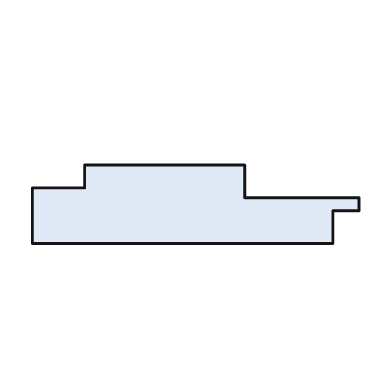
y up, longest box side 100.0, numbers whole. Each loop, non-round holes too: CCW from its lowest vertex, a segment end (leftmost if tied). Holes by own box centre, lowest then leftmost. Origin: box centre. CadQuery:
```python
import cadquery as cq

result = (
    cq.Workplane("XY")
    .moveTo(-50.0, -12.0)
    .lineTo(42.0, -12.0)
    .lineTo(42.0, -2.0)
    .lineTo(50.0, -2.0)
    .lineTo(50.0, 2.0)
    .lineTo(15.0, 2.0)
    .lineTo(15.0, 12.0)
    .lineTo(-34.0, 12.0)
    .lineTo(-34.0, 5.0)
    .lineTo(-50.0, 5.0)
    .close()
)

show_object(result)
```